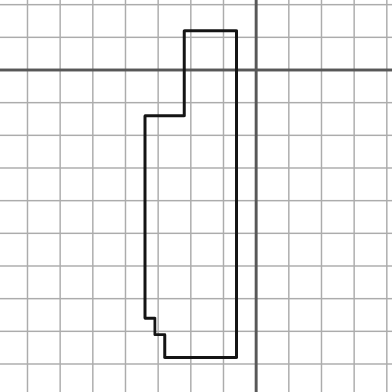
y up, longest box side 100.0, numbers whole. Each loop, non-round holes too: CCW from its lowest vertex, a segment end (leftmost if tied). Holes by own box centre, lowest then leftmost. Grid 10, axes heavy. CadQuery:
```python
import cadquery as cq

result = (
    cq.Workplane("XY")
    .moveTo(-28.0, -88.0)
    .lineTo(-6.0, -88.0)
    .lineTo(-6.0, 12.0)
    .lineTo(-22.0, 12.0)
    .lineTo(-22.0, -14.0)
    .lineTo(-34.0, -14.0)
    .lineTo(-34.0, -76.0)
    .lineTo(-31.0, -76.0)
    .lineTo(-31.0, -81.0)
    .lineTo(-28.0, -81.0)
    .close()
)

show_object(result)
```